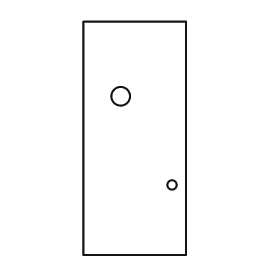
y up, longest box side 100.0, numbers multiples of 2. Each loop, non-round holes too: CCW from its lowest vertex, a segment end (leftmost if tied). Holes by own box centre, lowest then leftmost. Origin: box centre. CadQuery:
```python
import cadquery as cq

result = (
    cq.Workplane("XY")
    .moveTo(-22.0, -50.0)
    .lineTo(22.0, -50.0)
    .lineTo(22.0, 50.0)
    .lineTo(-22.0, 50.0)
    .close()
    .moveTo(16.0, -20.0)
    .circle(2.0)
    .moveTo(-6.0, 18.0)
    .circle(4.0)
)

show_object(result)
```